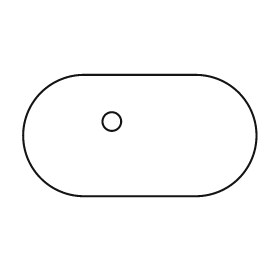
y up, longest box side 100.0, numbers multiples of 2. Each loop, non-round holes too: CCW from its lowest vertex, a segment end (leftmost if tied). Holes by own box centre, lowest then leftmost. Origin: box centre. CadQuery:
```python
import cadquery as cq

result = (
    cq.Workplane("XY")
    .moveTo(-24.0, -26.0)
    .lineTo(24.0, -26.0)
    .threePointArc((50.0, 0.0), (24.0, 26.0))
    .lineTo(-24.0, 26.0)
    .threePointArc((-50.0, 0.0), (-24.0, -26.0))
    .close()
    .moveTo(-12.0, 6.0)
    .circle(4.0)
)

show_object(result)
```